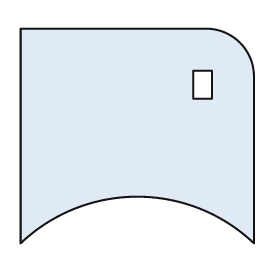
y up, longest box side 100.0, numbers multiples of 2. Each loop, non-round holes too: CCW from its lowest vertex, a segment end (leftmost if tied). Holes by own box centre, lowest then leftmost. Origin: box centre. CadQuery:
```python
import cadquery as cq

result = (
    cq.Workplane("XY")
    .moveTo(-50.0, -46.0)
    .threePointArc((0.0, -26.0), (50.0, -46.0))
    .lineTo(50.0, 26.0)
    .threePointArc((44.0, 40.0), (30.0, 46.0))
    .lineTo(-50.0, 46.0)
    .close()
    .moveTo(24.0, 16.0)
    .lineTo(32.0, 16.0)
    .lineTo(32.0, 28.0)
    .lineTo(24.0, 28.0)
    .close()
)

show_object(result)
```